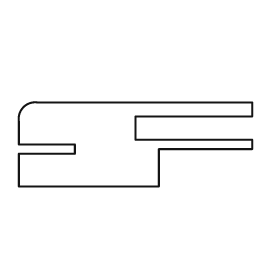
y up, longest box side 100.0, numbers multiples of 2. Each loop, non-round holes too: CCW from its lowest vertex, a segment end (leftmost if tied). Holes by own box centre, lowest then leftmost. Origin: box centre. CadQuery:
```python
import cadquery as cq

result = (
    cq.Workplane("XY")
    .moveTo(-50.0, -18.0)
    .lineTo(10.0, -18.0)
    .lineTo(10.0, -2.0)
    .lineTo(50.0, -2.0)
    .lineTo(50.0, 2.0)
    .lineTo(0.0, 2.0)
    .lineTo(0.0, 12.0)
    .lineTo(50.0, 12.0)
    .lineTo(50.0, 18.0)
    .lineTo(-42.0, 18.0)
    .threePointArc((-48.0, 16.0), (-50.0, 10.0))
    .lineTo(-50.0, 0.0)
    .lineTo(-26.0, 0.0)
    .lineTo(-26.0, -4.0)
    .lineTo(-50.0, -4.0)
    .close()
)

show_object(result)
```